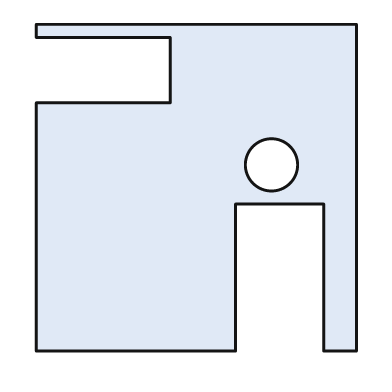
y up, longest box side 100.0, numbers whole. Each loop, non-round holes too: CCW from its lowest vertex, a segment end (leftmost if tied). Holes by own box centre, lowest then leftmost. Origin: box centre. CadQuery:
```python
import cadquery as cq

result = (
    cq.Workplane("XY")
    .moveTo(-49.0, -50.0)
    .lineTo(12.0, -50.0)
    .lineTo(12.0, -5.0)
    .lineTo(39.0, -5.0)
    .lineTo(39.0, -50.0)
    .lineTo(49.0, -50.0)
    .lineTo(49.0, 50.0)
    .lineTo(-49.0, 50.0)
    .lineTo(-49.0, 46.0)
    .lineTo(-8.0, 46.0)
    .lineTo(-8.0, 26.0)
    .lineTo(-49.0, 26.0)
    .close()
    .moveTo(23.0, 7.0)
    .circle(8.0)
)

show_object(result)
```